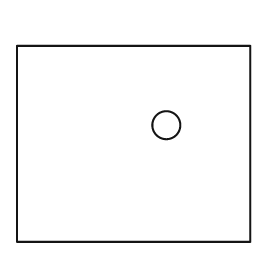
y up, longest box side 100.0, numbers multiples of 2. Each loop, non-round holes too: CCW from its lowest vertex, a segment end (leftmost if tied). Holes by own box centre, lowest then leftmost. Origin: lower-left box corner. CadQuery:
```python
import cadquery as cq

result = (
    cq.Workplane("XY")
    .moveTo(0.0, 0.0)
    .lineTo(100.0, 0.0)
    .lineTo(100.0, 84.0)
    .lineTo(0.0, 84.0)
    .close()
    .moveTo(64.0, 50.0)
    .circle(6.0)
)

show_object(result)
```